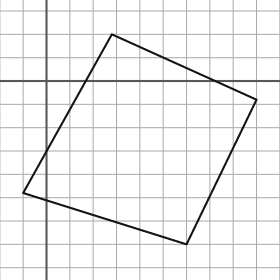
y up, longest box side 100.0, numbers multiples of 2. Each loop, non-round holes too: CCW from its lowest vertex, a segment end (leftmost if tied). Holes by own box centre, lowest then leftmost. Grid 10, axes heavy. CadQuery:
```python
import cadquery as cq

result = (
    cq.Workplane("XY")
    .moveTo(60.0, -70.0)
    .lineTo(90.0, -8.0)
    .lineTo(28.0, 20.0)
    .lineTo(-10.0, -48.0)
    .close()
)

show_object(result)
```